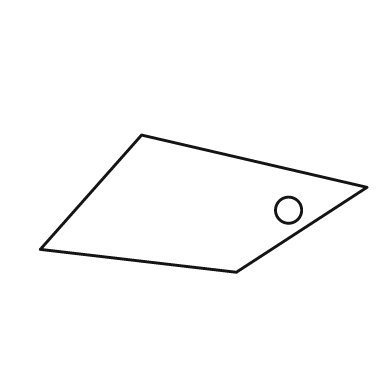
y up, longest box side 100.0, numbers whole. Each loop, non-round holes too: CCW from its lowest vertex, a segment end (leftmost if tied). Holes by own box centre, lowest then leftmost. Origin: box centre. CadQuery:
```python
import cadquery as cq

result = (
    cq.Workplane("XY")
    .moveTo(10.0, -21.0)
    .lineTo(50.0, 5.0)
    .lineTo(-19.0, 21.0)
    .lineTo(-50.0, -14.0)
    .close()
    .moveTo(26.0, -2.0)
    .circle(4.0)
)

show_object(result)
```